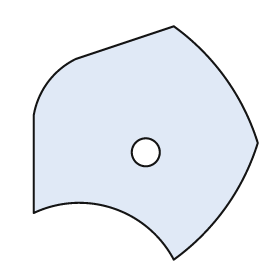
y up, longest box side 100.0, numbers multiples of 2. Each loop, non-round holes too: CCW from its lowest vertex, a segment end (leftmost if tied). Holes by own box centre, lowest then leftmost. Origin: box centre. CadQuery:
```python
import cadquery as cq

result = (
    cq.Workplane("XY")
    .moveTo(12.0, -50.0)
    .threePointArc((34.0, -28.0), (48.0, 0.0))
    .threePointArc((34.0, 28.0), (12.0, 50.0))
    .lineTo(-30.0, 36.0)
    .threePointArc((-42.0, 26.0), (-48.0, 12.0))
    .lineTo(-48.0, -30.0)
    .threePointArc((-14.0, -28.0), (12.0, -50.0))
    .close()
    .moveTo(0.0, -4.0)
    .circle(6.0)
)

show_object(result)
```